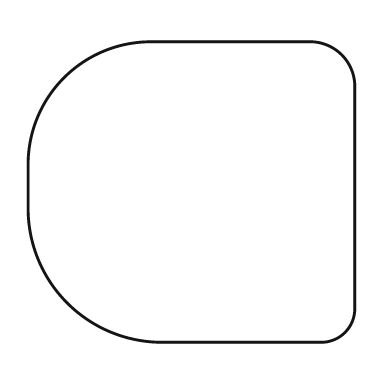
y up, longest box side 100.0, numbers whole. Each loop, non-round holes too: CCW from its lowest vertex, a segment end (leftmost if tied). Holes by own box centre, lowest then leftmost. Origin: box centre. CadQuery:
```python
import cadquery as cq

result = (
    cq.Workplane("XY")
    .moveTo(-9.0, -46.0)
    .lineTo(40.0, -46.0)
    .threePointArc((47.0, -43.0), (50.0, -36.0))
    .lineTo(50.0, 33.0)
    .threePointArc((46.0, 42.0), (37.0, 46.0))
    .lineTo(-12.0, 46.0)
    .threePointArc((-39.0, 35.0), (-50.0, 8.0))
    .lineTo(-50.0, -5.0)
    .threePointArc((-38.0, -34.0), (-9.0, -46.0))
    .close()
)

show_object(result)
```